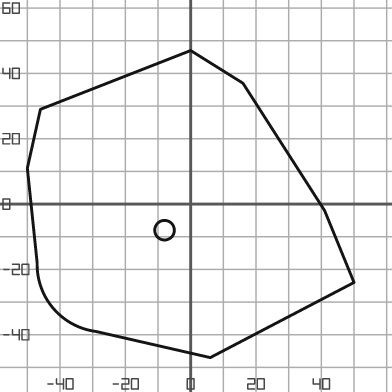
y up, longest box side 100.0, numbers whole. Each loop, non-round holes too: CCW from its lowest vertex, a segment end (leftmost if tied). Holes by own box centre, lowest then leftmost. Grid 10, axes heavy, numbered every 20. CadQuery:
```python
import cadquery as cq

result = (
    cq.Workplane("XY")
    .moveTo(6.0, -47.0)
    .lineTo(50.0, -24.0)
    .lineTo(41.0, -2.0)
    .lineTo(16.0, 37.0)
    .lineTo(0.0, 47.0)
    .lineTo(-46.0, 29.0)
    .lineTo(-50.0, 11.0)
    .lineTo(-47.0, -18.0)
    .threePointArc((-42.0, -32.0), (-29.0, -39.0))
    .close()
    .moveTo(-8.0, -8.0)
    .circle(3.0)
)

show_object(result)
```